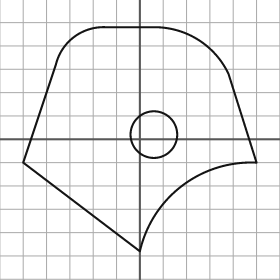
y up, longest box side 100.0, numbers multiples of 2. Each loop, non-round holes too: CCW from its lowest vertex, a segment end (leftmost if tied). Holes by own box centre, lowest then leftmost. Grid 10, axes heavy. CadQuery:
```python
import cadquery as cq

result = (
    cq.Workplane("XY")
    .moveTo(0.0, -48.0)
    .threePointArc((18.0, -20.0), (50.0, -10.0))
    .lineTo(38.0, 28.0)
    .threePointArc((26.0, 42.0), (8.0, 48.0))
    .lineTo(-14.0, 48.0)
    .threePointArc((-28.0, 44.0), (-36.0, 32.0))
    .lineTo(-50.0, -10.0)
    .close()
    .moveTo(6.0, 2.0)
    .circle(10.0)
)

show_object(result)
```